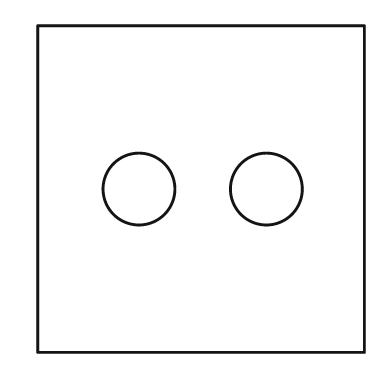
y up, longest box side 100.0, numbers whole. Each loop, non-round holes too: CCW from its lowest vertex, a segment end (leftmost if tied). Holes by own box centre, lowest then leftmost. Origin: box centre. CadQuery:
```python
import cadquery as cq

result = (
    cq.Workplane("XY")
    .moveTo(-50.0, -50.0)
    .lineTo(50.0, -50.0)
    .lineTo(50.0, 50.0)
    .lineTo(-50.0, 50.0)
    .close()
    .moveTo(-19.0, 0.0)
    .circle(11.0)
    .moveTo(20.0, 0.0)
    .circle(11.0)
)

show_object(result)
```